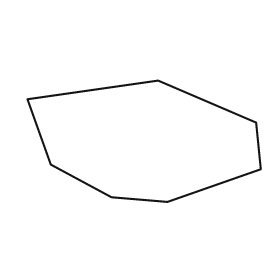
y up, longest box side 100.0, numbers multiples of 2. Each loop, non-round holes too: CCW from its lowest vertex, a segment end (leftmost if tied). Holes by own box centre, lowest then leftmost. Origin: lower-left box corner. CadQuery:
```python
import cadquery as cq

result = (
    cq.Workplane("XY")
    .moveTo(60.0, 0.0)
    .lineTo(100.0, 14.0)
    .lineTo(98.0, 34.0)
    .lineTo(56.0, 52.0)
    .lineTo(0.0, 44.0)
    .lineTo(10.0, 16.0)
    .lineTo(36.0, 2.0)
    .close()
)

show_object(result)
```